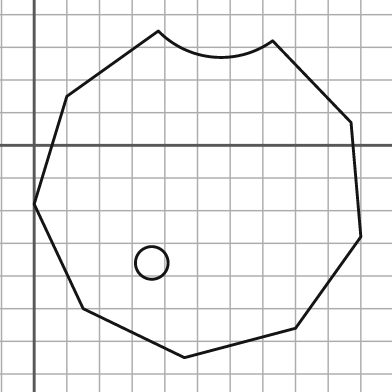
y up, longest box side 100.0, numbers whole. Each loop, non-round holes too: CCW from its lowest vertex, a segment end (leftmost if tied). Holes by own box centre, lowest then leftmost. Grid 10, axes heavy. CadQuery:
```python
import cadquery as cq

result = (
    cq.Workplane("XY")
    .moveTo(46.0, -65.0)
    .lineTo(80.0, -56.0)
    .lineTo(100.0, -28.0)
    .lineTo(97.0, 7.0)
    .lineTo(73.0, 32.0)
    .threePointArc((55.0, 27.0), (38.0, 35.0))
    .lineTo(10.0, 15.0)
    .lineTo(0.0, -18.0)
    .lineTo(15.0, -50.0)
    .close()
    .moveTo(36.0, -36.0)
    .circle(5.0)
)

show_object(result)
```